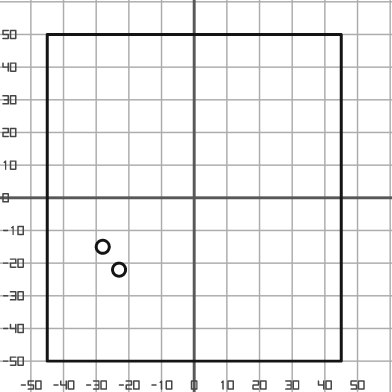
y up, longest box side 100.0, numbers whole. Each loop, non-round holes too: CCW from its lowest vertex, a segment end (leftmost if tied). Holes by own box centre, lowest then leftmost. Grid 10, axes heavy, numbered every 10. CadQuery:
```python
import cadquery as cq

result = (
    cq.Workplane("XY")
    .moveTo(-45.0, -50.0)
    .lineTo(45.0, -50.0)
    .lineTo(45.0, 50.0)
    .lineTo(-45.0, 50.0)
    .close()
    .moveTo(-23.0, -22.0)
    .circle(2.0)
    .moveTo(-28.0, -15.0)
    .circle(2.0)
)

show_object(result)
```